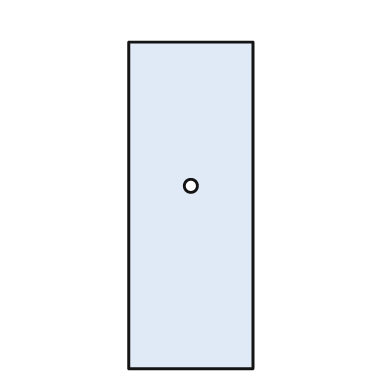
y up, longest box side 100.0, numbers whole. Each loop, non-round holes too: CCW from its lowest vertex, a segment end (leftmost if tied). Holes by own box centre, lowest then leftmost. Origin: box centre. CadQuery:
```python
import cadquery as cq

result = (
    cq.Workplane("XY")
    .moveTo(-19.0, -50.0)
    .lineTo(19.0, -50.0)
    .lineTo(19.0, 50.0)
    .lineTo(-19.0, 50.0)
    .close()
    .moveTo(0.0, 6.0)
    .circle(2.0)
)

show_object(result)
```